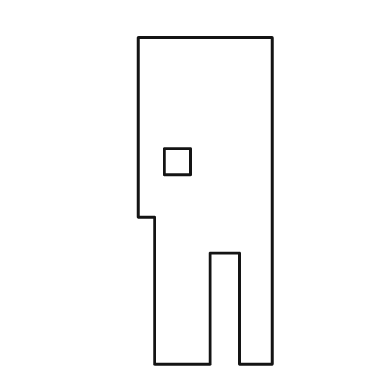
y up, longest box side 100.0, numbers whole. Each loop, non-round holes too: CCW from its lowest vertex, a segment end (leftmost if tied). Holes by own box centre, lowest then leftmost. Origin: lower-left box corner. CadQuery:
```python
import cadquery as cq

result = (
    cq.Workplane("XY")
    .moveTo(5.0, 0.0)
    .lineTo(22.0, 0.0)
    .lineTo(22.0, 34.0)
    .lineTo(31.0, 34.0)
    .lineTo(31.0, 0.0)
    .lineTo(41.0, 0.0)
    .lineTo(41.0, 100.0)
    .lineTo(0.0, 100.0)
    .lineTo(0.0, 45.0)
    .lineTo(5.0, 45.0)
    .close()
    .moveTo(8.0, 58.0)
    .lineTo(16.0, 58.0)
    .lineTo(16.0, 66.0)
    .lineTo(8.0, 66.0)
    .close()
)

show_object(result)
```